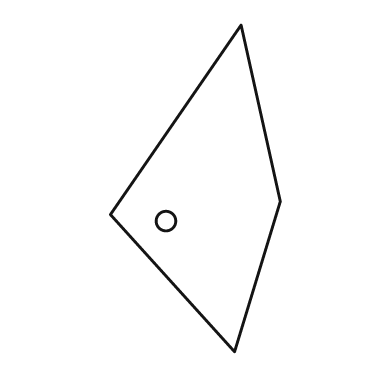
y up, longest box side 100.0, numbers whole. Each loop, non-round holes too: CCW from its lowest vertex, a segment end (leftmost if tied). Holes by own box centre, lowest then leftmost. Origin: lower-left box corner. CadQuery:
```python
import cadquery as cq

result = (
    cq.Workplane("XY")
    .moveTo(38.0, 0.0)
    .lineTo(52.0, 46.0)
    .lineTo(40.0, 100.0)
    .lineTo(0.0, 42.0)
    .close()
    .moveTo(17.0, 40.0)
    .circle(3.0)
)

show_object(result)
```